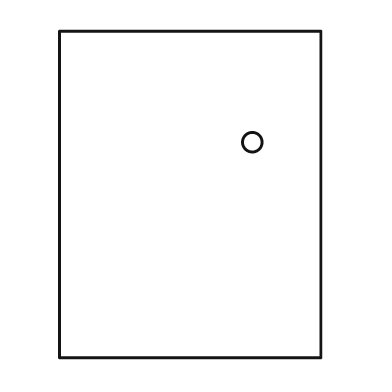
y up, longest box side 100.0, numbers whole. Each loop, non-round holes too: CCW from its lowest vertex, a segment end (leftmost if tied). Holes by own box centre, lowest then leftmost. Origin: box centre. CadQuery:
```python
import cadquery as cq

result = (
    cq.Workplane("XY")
    .moveTo(-40.0, -50.0)
    .lineTo(40.0, -50.0)
    .lineTo(40.0, 50.0)
    .lineTo(-40.0, 50.0)
    .close()
    .moveTo(19.0, 16.0)
    .circle(3.0)
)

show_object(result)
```